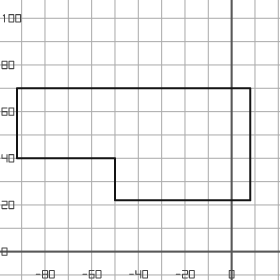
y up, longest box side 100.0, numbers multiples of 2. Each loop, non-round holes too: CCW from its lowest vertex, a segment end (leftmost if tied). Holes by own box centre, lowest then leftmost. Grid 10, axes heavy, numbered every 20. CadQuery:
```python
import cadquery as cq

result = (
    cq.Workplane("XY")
    .moveTo(-50.0, 22.0)
    .lineTo(8.0, 22.0)
    .lineTo(8.0, 70.0)
    .lineTo(-92.0, 70.0)
    .lineTo(-92.0, 40.0)
    .lineTo(-50.0, 40.0)
    .close()
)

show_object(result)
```